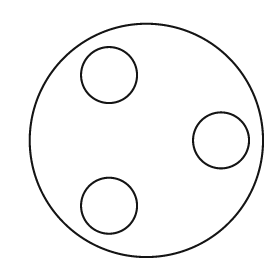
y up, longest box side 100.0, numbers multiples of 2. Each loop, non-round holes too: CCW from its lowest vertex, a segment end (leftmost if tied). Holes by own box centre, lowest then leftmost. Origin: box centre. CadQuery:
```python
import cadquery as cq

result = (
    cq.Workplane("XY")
    .moveTo(0.0, 0.0)
    .circle(50.0)
    .moveTo(-16.0, -28.0)
    .circle(12.0)
    .moveTo(32.0, 0.0)
    .circle(12.0)
    .moveTo(-16.0, 28.0)
    .circle(12.0)
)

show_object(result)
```